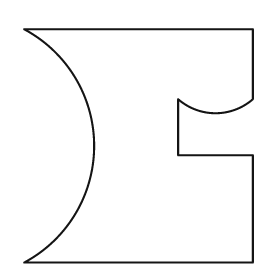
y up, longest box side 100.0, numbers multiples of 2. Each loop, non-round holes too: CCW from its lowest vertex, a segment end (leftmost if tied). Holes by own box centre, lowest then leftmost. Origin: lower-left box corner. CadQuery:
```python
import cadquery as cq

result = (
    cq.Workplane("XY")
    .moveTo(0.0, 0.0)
    .lineTo(98.0, 0.0)
    .lineTo(98.0, 46.0)
    .lineTo(66.0, 46.0)
    .lineTo(66.0, 70.0)
    .threePointArc((82.0, 64.0), (98.0, 70.0))
    .lineTo(98.0, 100.0)
    .lineTo(0.0, 100.0)
    .threePointArc((30.0, 50.0), (0.0, 0.0))
    .close()
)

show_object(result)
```